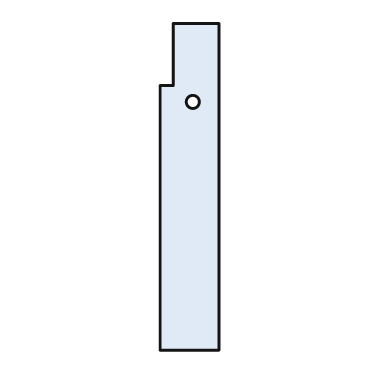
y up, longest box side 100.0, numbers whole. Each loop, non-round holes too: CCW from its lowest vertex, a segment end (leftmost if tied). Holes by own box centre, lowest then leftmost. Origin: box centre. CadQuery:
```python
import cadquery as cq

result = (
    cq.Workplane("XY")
    .moveTo(-9.0, -50.0)
    .lineTo(9.0, -50.0)
    .lineTo(9.0, 50.0)
    .lineTo(-5.0, 50.0)
    .lineTo(-5.0, 31.0)
    .lineTo(-9.0, 31.0)
    .close()
    .moveTo(1.0, 26.0)
    .circle(2.0)
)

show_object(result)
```